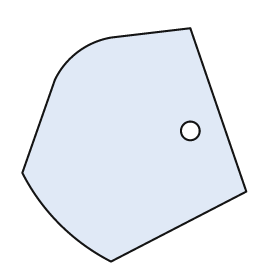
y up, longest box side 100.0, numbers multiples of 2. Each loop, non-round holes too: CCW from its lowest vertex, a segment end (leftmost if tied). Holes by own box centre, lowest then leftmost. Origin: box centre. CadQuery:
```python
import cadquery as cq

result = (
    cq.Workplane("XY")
    .moveTo(-10.0, -50.0)
    .lineTo(48.0, -20.0)
    .lineTo(24.0, 50.0)
    .lineTo(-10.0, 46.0)
    .threePointArc((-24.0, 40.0), (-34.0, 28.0))
    .lineTo(-48.0, -12.0)
    .threePointArc((-32.0, -34.0), (-10.0, -50.0))
    .close()
    .moveTo(24.0, 6.0)
    .circle(4.0)
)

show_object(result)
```